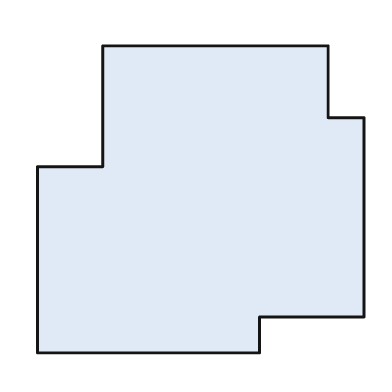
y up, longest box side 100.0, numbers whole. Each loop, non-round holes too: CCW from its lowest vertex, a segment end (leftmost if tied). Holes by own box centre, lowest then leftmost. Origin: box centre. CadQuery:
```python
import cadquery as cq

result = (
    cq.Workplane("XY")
    .moveTo(-50.0, -47.0)
    .lineTo(18.0, -47.0)
    .lineTo(18.0, -36.0)
    .lineTo(50.0, -36.0)
    .lineTo(50.0, 25.0)
    .lineTo(39.0, 25.0)
    .lineTo(39.0, 47.0)
    .lineTo(-30.0, 47.0)
    .lineTo(-30.0, 10.0)
    .lineTo(-50.0, 10.0)
    .close()
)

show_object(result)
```